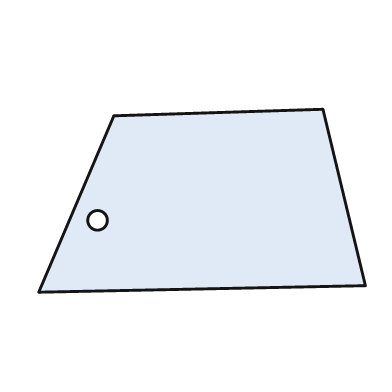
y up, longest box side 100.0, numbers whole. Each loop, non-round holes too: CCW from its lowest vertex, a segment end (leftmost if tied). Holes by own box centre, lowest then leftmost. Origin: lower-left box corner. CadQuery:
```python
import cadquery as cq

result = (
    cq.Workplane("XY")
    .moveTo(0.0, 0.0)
    .lineTo(100.0, 2.0)
    .lineTo(87.0, 56.0)
    .lineTo(23.0, 54.0)
    .close()
    .moveTo(18.0, 22.0)
    .circle(3.0)
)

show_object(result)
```